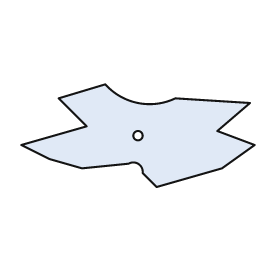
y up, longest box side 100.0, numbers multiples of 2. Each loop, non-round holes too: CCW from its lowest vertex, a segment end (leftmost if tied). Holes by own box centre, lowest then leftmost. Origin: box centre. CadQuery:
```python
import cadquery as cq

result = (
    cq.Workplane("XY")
    .moveTo(8.0, -22.0)
    .lineTo(36.0, -14.0)
    .lineTo(50.0, -4.0)
    .lineTo(34.0, 2.0)
    .lineTo(48.0, 14.0)
    .lineTo(16.0, 16.0)
    .threePointArc((0.0, 14.0), (-14.0, 22.0))
    .lineTo(-34.0, 16.0)
    .lineTo(-22.0, 4.0)
    .lineTo(-50.0, -4.0)
    .lineTo(-38.0, -10.0)
    .lineTo(-24.0, -14.0)
    .lineTo(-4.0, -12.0)
    .threePointArc((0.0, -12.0), (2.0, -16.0))
    .close()
    .moveTo(0.0, 0.0)
    .circle(2.0)
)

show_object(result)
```